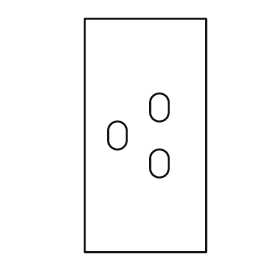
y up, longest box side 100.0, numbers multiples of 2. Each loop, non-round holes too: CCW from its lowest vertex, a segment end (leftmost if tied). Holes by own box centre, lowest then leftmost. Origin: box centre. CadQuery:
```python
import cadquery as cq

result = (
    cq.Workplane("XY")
    .moveTo(-26.0, -50.0)
    .lineTo(26.0, -50.0)
    .lineTo(26.0, 50.0)
    .lineTo(-26.0, 50.0)
    .close()
    .moveTo(2.0, -14.0)
    .threePointArc((6.0, -18.0), (10.0, -14.0))
    .lineTo(10.0, -10.0)
    .threePointArc((6.0, -6.0), (2.0, -10.0))
    .close()
    .moveTo(-16.0, -2.0)
    .threePointArc((-12.0, -6.0), (-8.0, -2.0))
    .lineTo(-8.0, 2.0)
    .threePointArc((-12.0, 6.0), (-16.0, 2.0))
    .close()
    .moveTo(2.0, 10.0)
    .threePointArc((6.0, 6.0), (10.0, 10.0))
    .lineTo(10.0, 14.0)
    .threePointArc((6.0, 18.0), (2.0, 14.0))
    .close()
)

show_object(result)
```